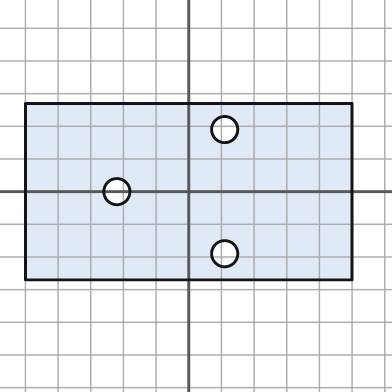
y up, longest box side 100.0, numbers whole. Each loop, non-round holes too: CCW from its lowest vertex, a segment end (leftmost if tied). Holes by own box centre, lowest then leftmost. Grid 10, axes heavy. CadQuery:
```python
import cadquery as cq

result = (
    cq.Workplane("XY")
    .moveTo(-50.0, -27.0)
    .lineTo(50.0, -27.0)
    .lineTo(50.0, 27.0)
    .lineTo(-50.0, 27.0)
    .close()
    .moveTo(11.0, -19.0)
    .circle(4.0)
    .moveTo(-22.0, 0.0)
    .circle(4.0)
    .moveTo(11.0, 19.0)
    .circle(4.0)
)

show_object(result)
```